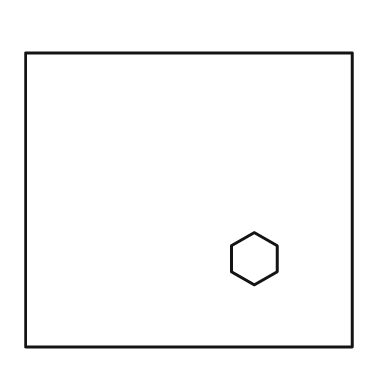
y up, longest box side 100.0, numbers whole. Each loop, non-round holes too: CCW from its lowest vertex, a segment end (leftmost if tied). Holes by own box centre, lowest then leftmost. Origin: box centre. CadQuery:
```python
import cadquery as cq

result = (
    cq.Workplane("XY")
    .moveTo(-50.0, -45.0)
    .lineTo(50.0, -45.0)
    .lineTo(50.0, 45.0)
    .lineTo(-50.0, 45.0)
    .close()
    .moveTo(20.0, -26.0)
    .lineTo(27.0, -22.0)
    .lineTo(27.0, -14.0)
    .lineTo(20.0, -10.0)
    .lineTo(13.0, -14.0)
    .lineTo(13.0, -22.0)
    .close()
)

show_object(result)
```